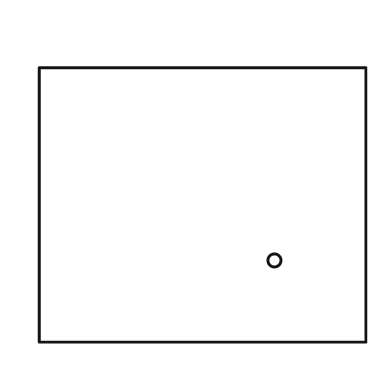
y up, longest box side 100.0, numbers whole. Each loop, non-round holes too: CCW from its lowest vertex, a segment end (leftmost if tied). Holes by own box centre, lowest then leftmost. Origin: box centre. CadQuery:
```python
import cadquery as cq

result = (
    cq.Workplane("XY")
    .moveTo(-50.0, -42.0)
    .lineTo(50.0, -42.0)
    .lineTo(50.0, 42.0)
    .lineTo(-50.0, 42.0)
    .close()
    .moveTo(22.0, -17.0)
    .circle(2.0)
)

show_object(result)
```